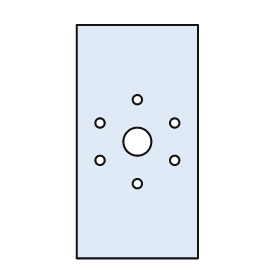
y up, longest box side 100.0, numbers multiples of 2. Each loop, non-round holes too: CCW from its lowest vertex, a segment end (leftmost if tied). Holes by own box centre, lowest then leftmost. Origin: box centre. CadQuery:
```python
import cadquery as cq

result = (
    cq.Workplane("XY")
    .moveTo(-26.0, -50.0)
    .lineTo(26.0, -50.0)
    .lineTo(26.0, 50.0)
    .lineTo(-26.0, 50.0)
    .close()
    .moveTo(0.0, -18.0)
    .circle(2.0)
    .moveTo(-16.0, -8.0)
    .circle(2.0)
    .moveTo(16.0, -8.0)
    .circle(2.0)
    .moveTo(0.0, 0.0)
    .circle(6.0)
    .moveTo(-16.0, 8.0)
    .circle(2.0)
    .moveTo(16.0, 8.0)
    .circle(2.0)
    .moveTo(0.0, 18.0)
    .circle(2.0)
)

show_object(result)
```